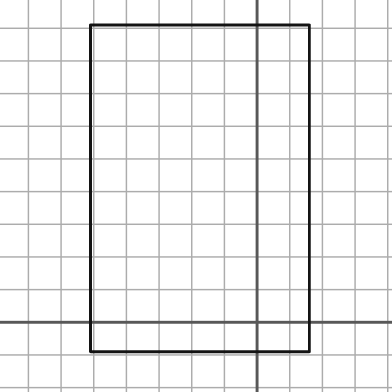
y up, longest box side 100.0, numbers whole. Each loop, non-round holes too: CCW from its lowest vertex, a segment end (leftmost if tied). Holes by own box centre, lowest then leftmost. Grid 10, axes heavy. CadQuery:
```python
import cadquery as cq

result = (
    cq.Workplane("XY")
    .moveTo(-51.0, -9.0)
    .lineTo(16.0, -9.0)
    .lineTo(16.0, 91.0)
    .lineTo(-51.0, 91.0)
    .close()
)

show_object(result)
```